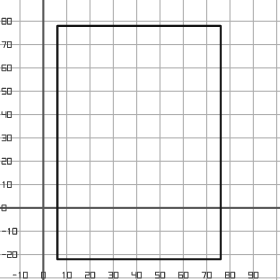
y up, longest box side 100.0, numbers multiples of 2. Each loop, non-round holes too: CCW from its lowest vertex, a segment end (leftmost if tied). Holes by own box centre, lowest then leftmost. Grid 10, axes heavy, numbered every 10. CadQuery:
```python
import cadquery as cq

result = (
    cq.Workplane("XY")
    .moveTo(6.0, -22.0)
    .lineTo(76.0, -22.0)
    .lineTo(76.0, 78.0)
    .lineTo(6.0, 78.0)
    .close()
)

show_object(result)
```